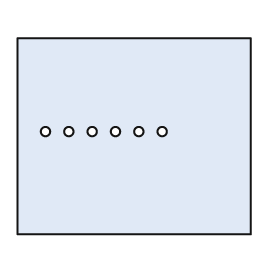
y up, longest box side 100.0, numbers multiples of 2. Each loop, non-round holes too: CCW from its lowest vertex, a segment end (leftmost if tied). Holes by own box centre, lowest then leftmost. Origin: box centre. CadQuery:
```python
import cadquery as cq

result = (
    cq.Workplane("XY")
    .moveTo(-50.0, -42.0)
    .lineTo(50.0, -42.0)
    .lineTo(50.0, 42.0)
    .lineTo(-50.0, 42.0)
    .close()
    .moveTo(-38.0, 2.0)
    .circle(2.0)
    .moveTo(-28.0, 2.0)
    .circle(2.0)
    .moveTo(-18.0, 2.0)
    .circle(2.0)
    .moveTo(-8.0, 2.0)
    .circle(2.0)
    .moveTo(2.0, 2.0)
    .circle(2.0)
    .moveTo(12.0, 2.0)
    .circle(2.0)
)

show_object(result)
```